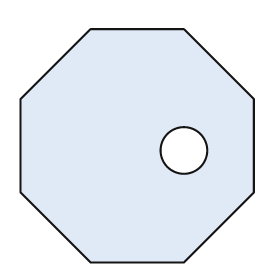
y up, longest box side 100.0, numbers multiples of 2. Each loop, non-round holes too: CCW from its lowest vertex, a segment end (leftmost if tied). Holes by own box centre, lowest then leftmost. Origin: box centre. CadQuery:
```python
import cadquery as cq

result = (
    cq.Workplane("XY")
    .moveTo(-20.0, -50.0)
    .lineTo(20.0, -50.0)
    .lineTo(50.0, -20.0)
    .lineTo(50.0, 20.0)
    .lineTo(20.0, 50.0)
    .lineTo(-20.0, 50.0)
    .lineTo(-50.0, 20.0)
    .lineTo(-50.0, -20.0)
    .close()
    .moveTo(20.0, -2.0)
    .circle(10.0)
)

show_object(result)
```